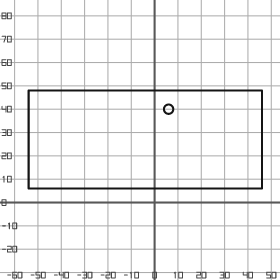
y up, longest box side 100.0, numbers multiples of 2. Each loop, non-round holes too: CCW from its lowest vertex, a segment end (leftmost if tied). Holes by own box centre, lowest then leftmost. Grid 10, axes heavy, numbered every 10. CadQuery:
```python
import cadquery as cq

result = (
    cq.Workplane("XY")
    .moveTo(-54.0, 6.0)
    .lineTo(46.0, 6.0)
    .lineTo(46.0, 48.0)
    .lineTo(-54.0, 48.0)
    .close()
    .moveTo(6.0, 40.0)
    .circle(2.0)
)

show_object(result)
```